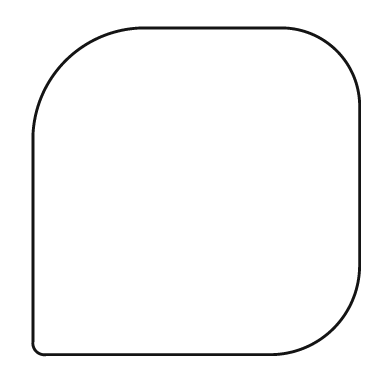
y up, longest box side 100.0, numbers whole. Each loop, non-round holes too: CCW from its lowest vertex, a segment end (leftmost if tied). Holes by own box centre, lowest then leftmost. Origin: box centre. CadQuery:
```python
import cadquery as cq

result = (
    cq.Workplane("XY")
    .moveTo(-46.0, -50.0)
    .lineTo(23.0, -50.0)
    .threePointArc((42.0, -42.0), (50.0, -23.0))
    .lineTo(50.0, 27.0)
    .threePointArc((43.0, 43.0), (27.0, 50.0))
    .lineTo(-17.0, 50.0)
    .threePointArc((-40.0, 40.0), (-50.0, 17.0))
    .lineTo(-50.0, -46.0)
    .threePointArc((-49.0, -49.0), (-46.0, -50.0))
    .close()
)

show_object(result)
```